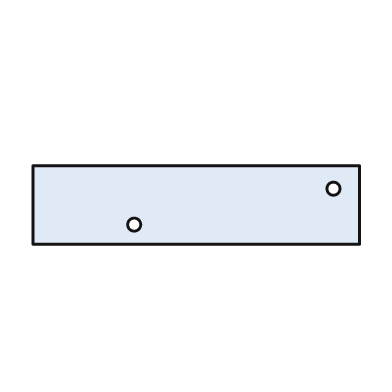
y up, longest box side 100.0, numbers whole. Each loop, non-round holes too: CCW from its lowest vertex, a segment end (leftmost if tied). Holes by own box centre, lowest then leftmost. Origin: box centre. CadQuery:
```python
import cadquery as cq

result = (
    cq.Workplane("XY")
    .moveTo(-50.0, -12.0)
    .lineTo(50.0, -12.0)
    .lineTo(50.0, 12.0)
    .lineTo(-50.0, 12.0)
    .close()
    .moveTo(-19.0, -6.0)
    .circle(2.0)
    .moveTo(42.0, 5.0)
    .circle(2.0)
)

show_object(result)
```